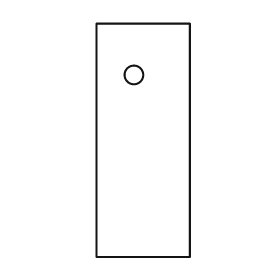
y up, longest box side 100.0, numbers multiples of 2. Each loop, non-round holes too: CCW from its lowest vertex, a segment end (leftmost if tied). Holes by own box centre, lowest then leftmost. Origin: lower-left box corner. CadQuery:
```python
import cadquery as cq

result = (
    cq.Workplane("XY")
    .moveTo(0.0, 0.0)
    .lineTo(40.0, 0.0)
    .lineTo(40.0, 100.0)
    .lineTo(0.0, 100.0)
    .close()
    .moveTo(16.0, 78.0)
    .circle(4.0)
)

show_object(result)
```